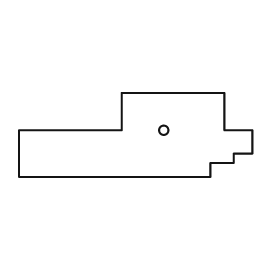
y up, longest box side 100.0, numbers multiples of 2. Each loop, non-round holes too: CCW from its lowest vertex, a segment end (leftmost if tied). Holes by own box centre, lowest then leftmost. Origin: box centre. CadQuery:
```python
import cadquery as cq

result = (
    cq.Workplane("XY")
    .moveTo(-50.0, -18.0)
    .lineTo(32.0, -18.0)
    .lineTo(32.0, -12.0)
    .lineTo(42.0, -12.0)
    .lineTo(42.0, -8.0)
    .lineTo(50.0, -8.0)
    .lineTo(50.0, 2.0)
    .lineTo(38.0, 2.0)
    .lineTo(38.0, 18.0)
    .lineTo(-6.0, 18.0)
    .lineTo(-6.0, 2.0)
    .lineTo(-50.0, 2.0)
    .close()
    .moveTo(12.0, 2.0)
    .circle(2.0)
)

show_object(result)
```